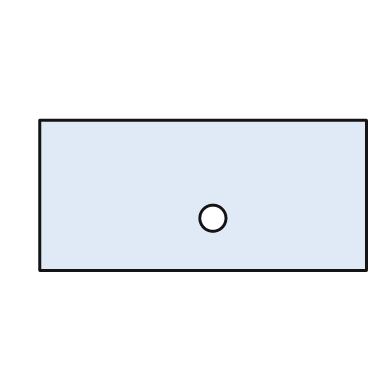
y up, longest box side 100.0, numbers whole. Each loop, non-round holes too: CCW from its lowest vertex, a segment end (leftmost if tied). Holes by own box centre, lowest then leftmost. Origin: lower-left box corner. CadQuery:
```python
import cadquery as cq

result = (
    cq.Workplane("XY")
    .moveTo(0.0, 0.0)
    .lineTo(100.0, 0.0)
    .lineTo(100.0, 46.0)
    .lineTo(0.0, 46.0)
    .close()
    .moveTo(53.0, 16.0)
    .circle(4.0)
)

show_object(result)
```